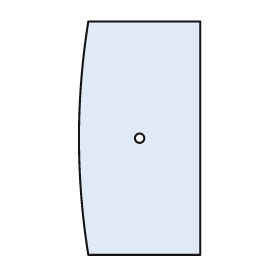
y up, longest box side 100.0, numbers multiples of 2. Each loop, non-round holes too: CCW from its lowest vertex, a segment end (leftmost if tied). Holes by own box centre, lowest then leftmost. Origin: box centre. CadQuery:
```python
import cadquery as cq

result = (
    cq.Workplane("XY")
    .moveTo(-22.0, -50.0)
    .lineTo(26.0, -50.0)
    .lineTo(26.0, 50.0)
    .lineTo(-22.0, 50.0)
    .threePointArc((-26.0, 0.0), (-22.0, -50.0))
    .close()
    .moveTo(0.0, 0.0)
    .circle(2.0)
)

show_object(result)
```